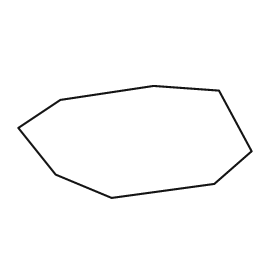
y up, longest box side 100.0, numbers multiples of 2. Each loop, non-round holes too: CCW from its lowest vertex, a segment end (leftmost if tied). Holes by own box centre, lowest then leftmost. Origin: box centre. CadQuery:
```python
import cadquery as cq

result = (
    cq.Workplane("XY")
    .moveTo(-10.0, -24.0)
    .lineTo(34.0, -18.0)
    .lineTo(50.0, -4.0)
    .lineTo(36.0, 22.0)
    .lineTo(8.0, 24.0)
    .lineTo(-32.0, 18.0)
    .lineTo(-50.0, 6.0)
    .lineTo(-34.0, -14.0)
    .close()
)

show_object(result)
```